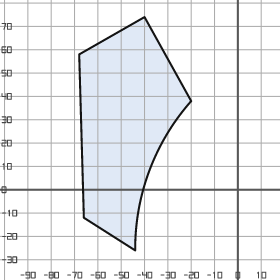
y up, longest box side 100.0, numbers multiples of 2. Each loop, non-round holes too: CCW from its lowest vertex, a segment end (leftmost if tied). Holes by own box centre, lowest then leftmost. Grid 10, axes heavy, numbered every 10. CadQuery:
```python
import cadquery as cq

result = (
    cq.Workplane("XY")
    .moveTo(-44.0, -26.0)
    .threePointArc((-38.0, 8.0), (-20.0, 38.0))
    .lineTo(-40.0, 74.0)
    .lineTo(-68.0, 58.0)
    .lineTo(-66.0, -12.0)
    .close()
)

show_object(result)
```